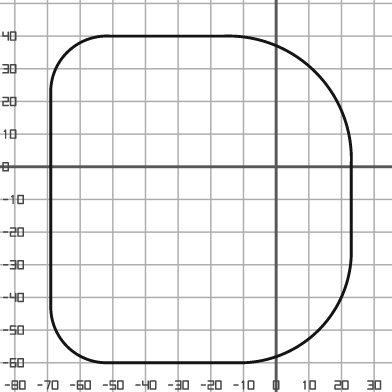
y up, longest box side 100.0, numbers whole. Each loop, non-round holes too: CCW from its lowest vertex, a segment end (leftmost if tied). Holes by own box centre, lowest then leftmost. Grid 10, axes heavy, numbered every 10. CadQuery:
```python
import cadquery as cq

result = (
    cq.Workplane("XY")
    .moveTo(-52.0, -60.0)
    .lineTo(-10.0, -60.0)
    .threePointArc((13.0, -50.0), (23.0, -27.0))
    .lineTo(23.0, 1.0)
    .threePointArc((12.0, 29.0), (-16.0, 40.0))
    .lineTo(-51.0, 40.0)
    .threePointArc((-64.0, 35.0), (-69.0, 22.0))
    .lineTo(-69.0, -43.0)
    .threePointArc((-64.0, -55.0), (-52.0, -60.0))
    .close()
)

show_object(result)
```